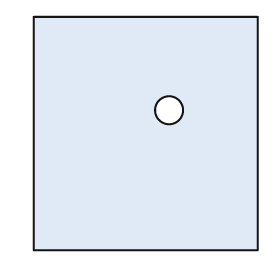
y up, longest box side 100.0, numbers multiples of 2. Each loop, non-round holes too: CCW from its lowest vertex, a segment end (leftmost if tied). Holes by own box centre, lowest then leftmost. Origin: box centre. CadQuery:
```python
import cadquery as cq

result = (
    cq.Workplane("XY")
    .moveTo(-48.0, -50.0)
    .lineTo(48.0, -50.0)
    .lineTo(48.0, 50.0)
    .lineTo(-48.0, 50.0)
    .close()
    .moveTo(10.0, 10.0)
    .circle(6.0)
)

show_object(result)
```